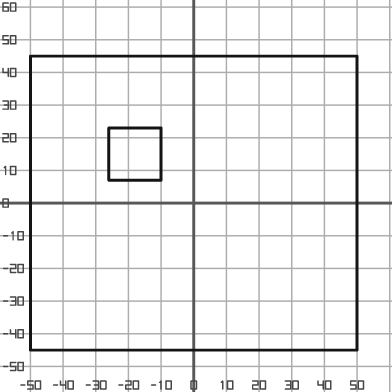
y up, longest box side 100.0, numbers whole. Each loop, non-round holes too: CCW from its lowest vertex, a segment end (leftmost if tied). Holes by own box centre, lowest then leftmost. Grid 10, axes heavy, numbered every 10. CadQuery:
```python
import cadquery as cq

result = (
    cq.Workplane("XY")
    .moveTo(-50.0, -45.0)
    .lineTo(50.0, -45.0)
    .lineTo(50.0, 45.0)
    .lineTo(-50.0, 45.0)
    .close()
    .moveTo(-26.0, 7.0)
    .lineTo(-10.0, 7.0)
    .lineTo(-10.0, 23.0)
    .lineTo(-26.0, 23.0)
    .close()
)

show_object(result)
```